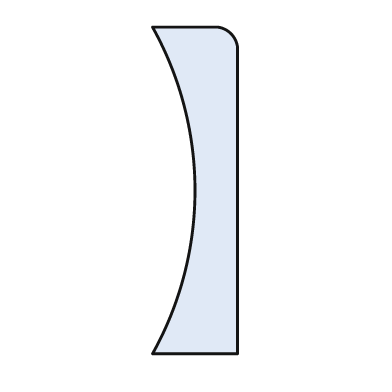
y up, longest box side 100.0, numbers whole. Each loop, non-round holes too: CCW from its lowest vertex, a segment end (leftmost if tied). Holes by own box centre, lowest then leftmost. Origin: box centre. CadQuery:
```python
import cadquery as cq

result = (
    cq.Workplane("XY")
    .moveTo(-13.0, -50.0)
    .lineTo(13.0, -50.0)
    .lineTo(13.0, 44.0)
    .threePointArc((11.0, 48.0), (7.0, 50.0))
    .lineTo(-13.0, 50.0)
    .threePointArc((0.0, 0.0), (-13.0, -50.0))
    .close()
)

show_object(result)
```